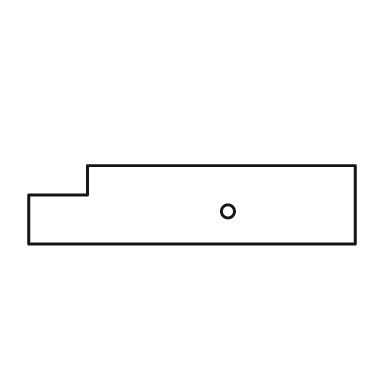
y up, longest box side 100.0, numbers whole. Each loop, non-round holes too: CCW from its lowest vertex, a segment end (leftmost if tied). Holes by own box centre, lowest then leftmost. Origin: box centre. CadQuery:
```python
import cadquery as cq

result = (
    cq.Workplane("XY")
    .moveTo(-50.0, -12.0)
    .lineTo(50.0, -12.0)
    .lineTo(50.0, 12.0)
    .lineTo(-32.0, 12.0)
    .lineTo(-32.0, 3.0)
    .lineTo(-50.0, 3.0)
    .close()
    .moveTo(11.0, -2.0)
    .circle(2.0)
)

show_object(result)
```